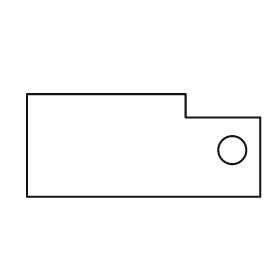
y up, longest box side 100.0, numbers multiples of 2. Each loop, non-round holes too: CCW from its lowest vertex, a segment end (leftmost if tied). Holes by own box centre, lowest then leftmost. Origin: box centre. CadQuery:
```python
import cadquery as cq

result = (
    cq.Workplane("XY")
    .moveTo(-50.0, -22.0)
    .lineTo(50.0, -22.0)
    .lineTo(50.0, 12.0)
    .lineTo(18.0, 12.0)
    .lineTo(18.0, 22.0)
    .lineTo(-50.0, 22.0)
    .close()
    .moveTo(38.0, -2.0)
    .circle(6.0)
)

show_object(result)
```